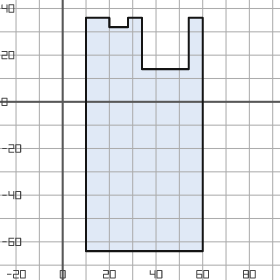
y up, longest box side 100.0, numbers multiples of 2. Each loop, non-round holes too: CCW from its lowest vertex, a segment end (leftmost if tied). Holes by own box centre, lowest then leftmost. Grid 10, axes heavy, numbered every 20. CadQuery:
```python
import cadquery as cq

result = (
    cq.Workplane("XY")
    .moveTo(10.0, -64.0)
    .lineTo(60.0, -64.0)
    .lineTo(60.0, 36.0)
    .lineTo(54.0, 36.0)
    .lineTo(54.0, 14.0)
    .lineTo(34.0, 14.0)
    .lineTo(34.0, 36.0)
    .lineTo(28.0, 36.0)
    .lineTo(28.0, 32.0)
    .lineTo(20.0, 32.0)
    .lineTo(20.0, 36.0)
    .lineTo(10.0, 36.0)
    .close()
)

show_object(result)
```